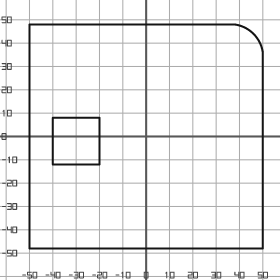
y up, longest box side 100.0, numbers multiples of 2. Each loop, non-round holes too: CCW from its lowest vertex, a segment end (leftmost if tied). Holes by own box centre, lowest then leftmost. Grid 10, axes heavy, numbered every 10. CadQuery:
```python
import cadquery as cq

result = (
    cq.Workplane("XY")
    .moveTo(-50.0, -48.0)
    .lineTo(50.0, -48.0)
    .lineTo(50.0, 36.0)
    .threePointArc((46.0, 44.0), (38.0, 48.0))
    .lineTo(-50.0, 48.0)
    .close()
    .moveTo(-40.0, -12.0)
    .lineTo(-20.0, -12.0)
    .lineTo(-20.0, 8.0)
    .lineTo(-40.0, 8.0)
    .close()
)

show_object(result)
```